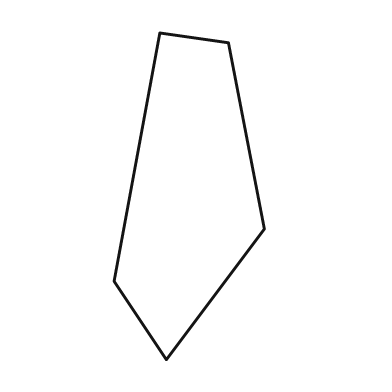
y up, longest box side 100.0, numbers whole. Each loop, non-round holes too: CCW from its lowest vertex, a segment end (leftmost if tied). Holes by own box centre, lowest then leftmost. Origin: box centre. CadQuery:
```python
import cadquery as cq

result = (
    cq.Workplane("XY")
    .moveTo(-7.0, -50.0)
    .lineTo(23.0, -10.0)
    .lineTo(12.0, 47.0)
    .lineTo(-9.0, 50.0)
    .lineTo(-23.0, -26.0)
    .close()
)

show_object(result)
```